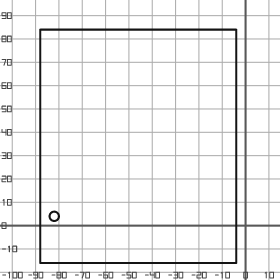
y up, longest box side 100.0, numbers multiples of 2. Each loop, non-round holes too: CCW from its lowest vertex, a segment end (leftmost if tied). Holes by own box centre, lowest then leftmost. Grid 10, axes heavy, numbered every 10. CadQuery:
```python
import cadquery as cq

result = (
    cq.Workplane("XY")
    .moveTo(-88.0, -16.0)
    .lineTo(-4.0, -16.0)
    .lineTo(-4.0, 84.0)
    .lineTo(-88.0, 84.0)
    .close()
    .moveTo(-82.0, 4.0)
    .circle(2.0)
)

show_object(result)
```